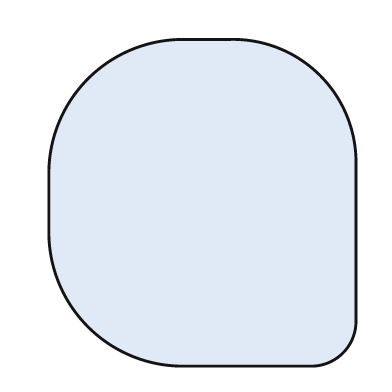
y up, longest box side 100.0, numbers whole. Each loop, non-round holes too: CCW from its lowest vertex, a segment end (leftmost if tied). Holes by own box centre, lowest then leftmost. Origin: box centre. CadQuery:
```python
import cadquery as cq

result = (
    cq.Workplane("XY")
    .moveTo(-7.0, -50.0)
    .lineTo(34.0, -50.0)
    .threePointArc((43.0, -46.0), (47.0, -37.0))
    .lineTo(47.0, 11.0)
    .threePointArc((36.0, 39.0), (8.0, 50.0))
    .lineTo(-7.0, 50.0)
    .threePointArc((-35.0, 38.0), (-47.0, 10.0))
    .lineTo(-47.0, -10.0)
    .threePointArc((-35.0, -38.0), (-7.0, -50.0))
    .close()
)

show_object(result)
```